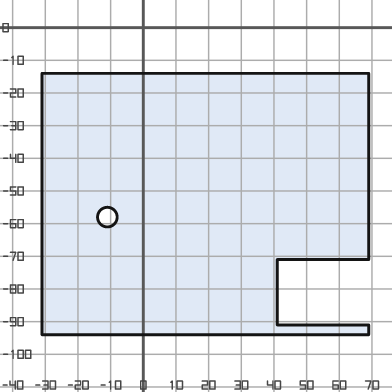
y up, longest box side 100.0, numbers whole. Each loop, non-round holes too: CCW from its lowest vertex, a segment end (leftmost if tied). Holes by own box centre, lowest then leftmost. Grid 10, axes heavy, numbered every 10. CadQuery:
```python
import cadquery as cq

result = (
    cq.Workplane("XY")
    .moveTo(-31.0, -94.0)
    .lineTo(69.0, -94.0)
    .lineTo(69.0, -91.0)
    .lineTo(41.0, -91.0)
    .lineTo(41.0, -71.0)
    .lineTo(69.0, -71.0)
    .lineTo(69.0, -14.0)
    .lineTo(-31.0, -14.0)
    .close()
    .moveTo(-11.0, -58.0)
    .circle(3.0)
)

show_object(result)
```